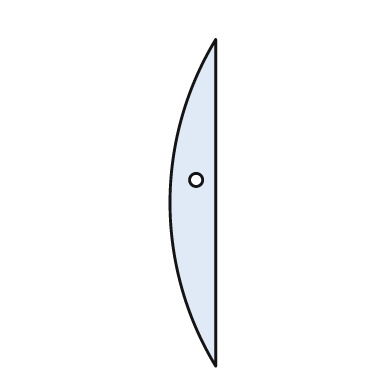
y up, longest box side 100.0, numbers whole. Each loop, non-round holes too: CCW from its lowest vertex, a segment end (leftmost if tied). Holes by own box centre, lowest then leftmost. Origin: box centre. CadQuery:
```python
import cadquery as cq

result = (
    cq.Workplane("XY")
    .moveTo(7.0, -50.0)
    .lineTo(7.0, 50.0)
    .threePointArc((-7.0, 0.0), (7.0, -50.0))
    .close()
    .moveTo(1.0, 7.0)
    .circle(2.0)
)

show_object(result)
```